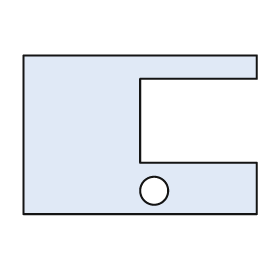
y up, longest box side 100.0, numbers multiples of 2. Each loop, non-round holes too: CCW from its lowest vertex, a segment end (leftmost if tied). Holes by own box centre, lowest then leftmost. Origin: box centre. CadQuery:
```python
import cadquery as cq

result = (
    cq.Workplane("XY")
    .moveTo(-50.0, -34.0)
    .lineTo(50.0, -34.0)
    .lineTo(50.0, -12.0)
    .lineTo(0.0, -12.0)
    .lineTo(0.0, 24.0)
    .lineTo(50.0, 24.0)
    .lineTo(50.0, 34.0)
    .lineTo(-50.0, 34.0)
    .close()
    .moveTo(6.0, -24.0)
    .circle(6.0)
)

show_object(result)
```